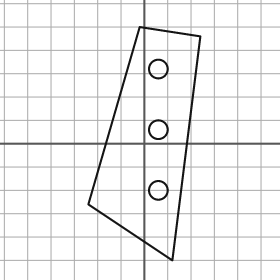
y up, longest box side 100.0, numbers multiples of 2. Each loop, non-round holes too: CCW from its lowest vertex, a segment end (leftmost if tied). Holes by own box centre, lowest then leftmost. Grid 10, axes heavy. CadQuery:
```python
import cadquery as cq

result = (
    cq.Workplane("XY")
    .moveTo(12.0, -50.0)
    .lineTo(24.0, 46.0)
    .lineTo(-2.0, 50.0)
    .lineTo(-24.0, -26.0)
    .close()
    .moveTo(6.0, -20.0)
    .circle(4.0)
    .moveTo(6.0, 6.0)
    .circle(4.0)
    .moveTo(6.0, 32.0)
    .circle(4.0)
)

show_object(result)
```